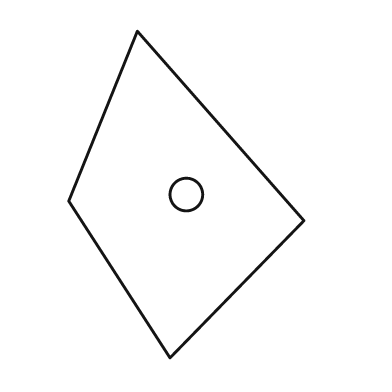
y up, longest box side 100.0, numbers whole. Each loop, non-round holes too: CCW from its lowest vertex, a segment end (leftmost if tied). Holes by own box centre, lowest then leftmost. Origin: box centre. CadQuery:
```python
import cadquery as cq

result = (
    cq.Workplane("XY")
    .moveTo(-5.0, -50.0)
    .lineTo(36.0, -8.0)
    .lineTo(-15.0, 50.0)
    .lineTo(-36.0, -2.0)
    .close()
    .moveTo(0.0, 0.0)
    .circle(5.0)
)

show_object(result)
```